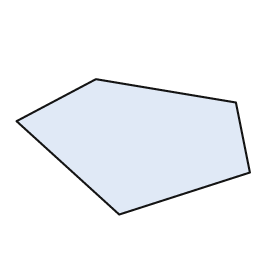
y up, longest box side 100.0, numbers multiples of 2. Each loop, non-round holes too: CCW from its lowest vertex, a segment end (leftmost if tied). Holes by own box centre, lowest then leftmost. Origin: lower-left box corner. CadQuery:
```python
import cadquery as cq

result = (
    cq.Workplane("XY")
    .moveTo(44.0, 0.0)
    .lineTo(100.0, 18.0)
    .lineTo(94.0, 48.0)
    .lineTo(34.0, 58.0)
    .lineTo(0.0, 40.0)
    .close()
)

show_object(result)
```